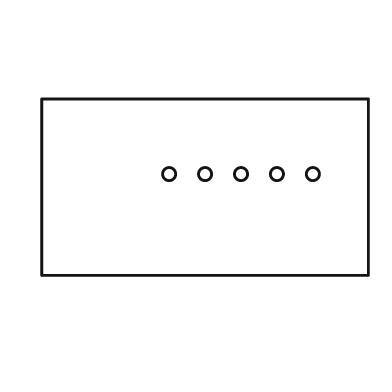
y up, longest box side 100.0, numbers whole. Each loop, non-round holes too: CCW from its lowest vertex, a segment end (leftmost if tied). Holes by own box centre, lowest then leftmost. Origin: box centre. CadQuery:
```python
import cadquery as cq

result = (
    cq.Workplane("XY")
    .moveTo(-50.0, -27.0)
    .lineTo(50.0, -27.0)
    .lineTo(50.0, 27.0)
    .lineTo(-50.0, 27.0)
    .close()
    .moveTo(-11.0, 4.0)
    .circle(2.0)
    .moveTo(0.0, 4.0)
    .circle(2.0)
    .moveTo(11.0, 4.0)
    .circle(2.0)
    .moveTo(22.0, 4.0)
    .circle(2.0)
    .moveTo(33.0, 4.0)
    .circle(2.0)
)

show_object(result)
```